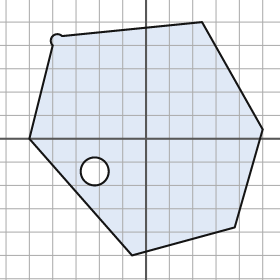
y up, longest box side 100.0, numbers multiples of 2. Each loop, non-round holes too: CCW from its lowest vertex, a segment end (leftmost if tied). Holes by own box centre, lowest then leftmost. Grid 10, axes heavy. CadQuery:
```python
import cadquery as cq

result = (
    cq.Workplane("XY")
    .moveTo(-6.0, -50.0)
    .lineTo(38.0, -38.0)
    .lineTo(50.0, 4.0)
    .lineTo(24.0, 50.0)
    .lineTo(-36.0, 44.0)
    .threePointArc((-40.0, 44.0), (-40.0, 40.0))
    .lineTo(-50.0, 0.0)
    .close()
    .moveTo(-22.0, -14.0)
    .circle(6.0)
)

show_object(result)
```